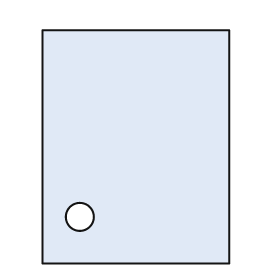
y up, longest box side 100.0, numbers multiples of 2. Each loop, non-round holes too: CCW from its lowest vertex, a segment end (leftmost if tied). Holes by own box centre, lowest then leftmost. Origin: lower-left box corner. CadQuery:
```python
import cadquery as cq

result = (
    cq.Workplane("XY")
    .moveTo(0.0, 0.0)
    .lineTo(80.0, 0.0)
    .lineTo(80.0, 100.0)
    .lineTo(0.0, 100.0)
    .close()
    .moveTo(16.0, 20.0)
    .circle(6.0)
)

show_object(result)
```